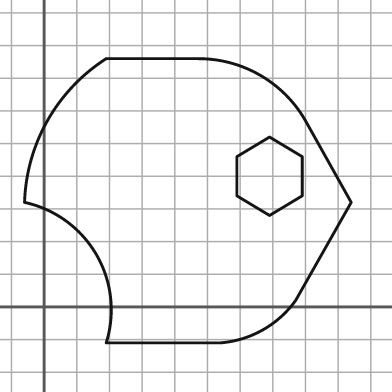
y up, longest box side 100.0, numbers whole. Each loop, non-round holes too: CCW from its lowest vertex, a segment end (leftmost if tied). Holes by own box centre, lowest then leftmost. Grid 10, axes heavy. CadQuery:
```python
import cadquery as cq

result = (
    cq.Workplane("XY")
    .moveTo(19.0, -11.0)
    .lineTo(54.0, -11.0)
    .threePointArc((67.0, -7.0), (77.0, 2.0))
    .lineTo(94.0, 32.0)
    .lineTo(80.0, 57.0)
    .threePointArc((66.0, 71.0), (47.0, 76.0))
    .lineTo(19.0, 76.0)
    .threePointArc((1.0, 57.0), (-6.0, 32.0))
    .threePointArc((16.0, 16.0), (19.0, -11.0))
    .close()
    .moveTo(69.0, 28.0)
    .lineTo(79.0, 34.0)
    .lineTo(79.0, 46.0)
    .lineTo(69.0, 52.0)
    .lineTo(59.0, 46.0)
    .lineTo(59.0, 34.0)
    .close()
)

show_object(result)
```